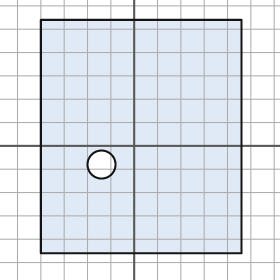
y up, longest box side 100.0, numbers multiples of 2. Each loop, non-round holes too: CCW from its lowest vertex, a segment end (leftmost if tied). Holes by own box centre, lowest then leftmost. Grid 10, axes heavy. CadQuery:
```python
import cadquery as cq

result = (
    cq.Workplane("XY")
    .moveTo(-40.0, -46.0)
    .lineTo(46.0, -46.0)
    .lineTo(46.0, 54.0)
    .lineTo(-40.0, 54.0)
    .close()
    .moveTo(-14.0, -8.0)
    .circle(6.0)
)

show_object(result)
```